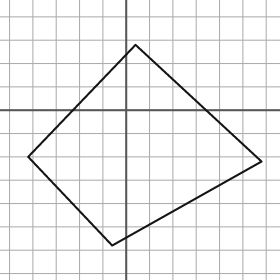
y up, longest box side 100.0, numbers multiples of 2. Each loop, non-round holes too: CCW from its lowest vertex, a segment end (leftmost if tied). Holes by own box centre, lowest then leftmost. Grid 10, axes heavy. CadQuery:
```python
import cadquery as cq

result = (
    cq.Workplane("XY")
    .moveTo(-6.0, -58.0)
    .lineTo(58.0, -22.0)
    .lineTo(4.0, 28.0)
    .lineTo(-42.0, -20.0)
    .close()
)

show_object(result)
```